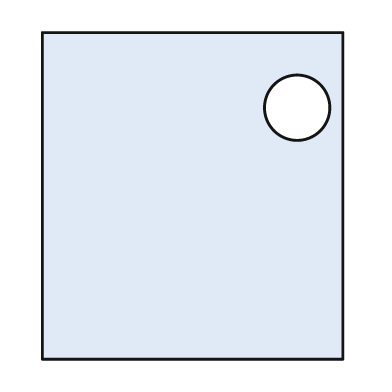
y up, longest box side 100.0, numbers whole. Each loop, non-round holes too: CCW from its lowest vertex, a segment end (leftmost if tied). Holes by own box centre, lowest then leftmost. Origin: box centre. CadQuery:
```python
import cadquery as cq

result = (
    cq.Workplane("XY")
    .moveTo(-46.0, -50.0)
    .lineTo(46.0, -50.0)
    .lineTo(46.0, 50.0)
    .lineTo(-46.0, 50.0)
    .close()
    .moveTo(32.0, 27.0)
    .circle(10.0)
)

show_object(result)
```